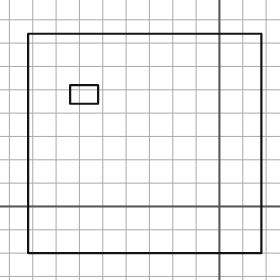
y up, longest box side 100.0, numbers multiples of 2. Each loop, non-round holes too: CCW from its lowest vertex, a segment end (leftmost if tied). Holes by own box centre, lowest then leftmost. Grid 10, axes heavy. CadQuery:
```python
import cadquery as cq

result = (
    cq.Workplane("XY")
    .moveTo(-82.0, -20.0)
    .lineTo(18.0, -20.0)
    .lineTo(18.0, 74.0)
    .lineTo(-82.0, 74.0)
    .close()
    .moveTo(-64.0, 44.0)
    .lineTo(-52.0, 44.0)
    .lineTo(-52.0, 52.0)
    .lineTo(-64.0, 52.0)
    .close()
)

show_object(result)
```